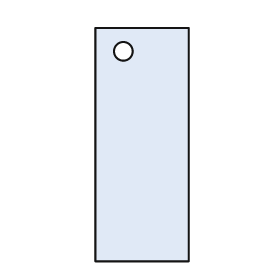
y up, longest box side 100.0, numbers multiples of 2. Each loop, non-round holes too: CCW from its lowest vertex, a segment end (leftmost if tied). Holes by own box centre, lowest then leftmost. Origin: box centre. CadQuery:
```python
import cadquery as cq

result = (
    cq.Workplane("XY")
    .moveTo(-20.0, -50.0)
    .lineTo(20.0, -50.0)
    .lineTo(20.0, 50.0)
    .lineTo(-20.0, 50.0)
    .close()
    .moveTo(-8.0, 40.0)
    .circle(4.0)
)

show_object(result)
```